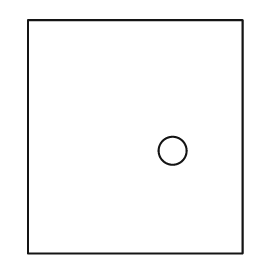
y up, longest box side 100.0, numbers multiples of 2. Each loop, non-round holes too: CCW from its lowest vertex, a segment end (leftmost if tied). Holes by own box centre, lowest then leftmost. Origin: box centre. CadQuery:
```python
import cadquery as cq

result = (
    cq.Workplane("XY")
    .moveTo(-46.0, -50.0)
    .lineTo(46.0, -50.0)
    .lineTo(46.0, 50.0)
    .lineTo(-46.0, 50.0)
    .close()
    .moveTo(16.0, -6.0)
    .circle(6.0)
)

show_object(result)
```